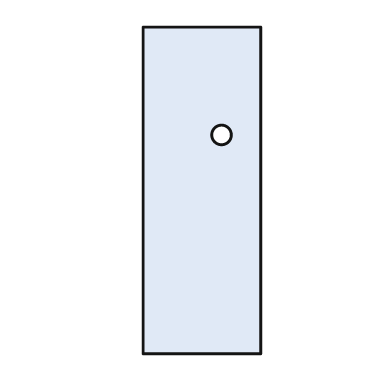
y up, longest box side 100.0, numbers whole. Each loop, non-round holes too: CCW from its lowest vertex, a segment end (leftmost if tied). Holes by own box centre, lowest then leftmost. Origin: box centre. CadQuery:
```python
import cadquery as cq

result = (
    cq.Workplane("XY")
    .moveTo(-18.0, -50.0)
    .lineTo(18.0, -50.0)
    .lineTo(18.0, 50.0)
    .lineTo(-18.0, 50.0)
    .close()
    .moveTo(6.0, 17.0)
    .circle(3.0)
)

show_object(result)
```